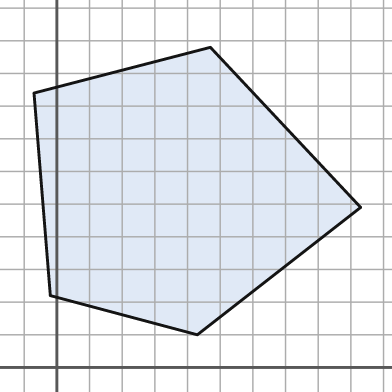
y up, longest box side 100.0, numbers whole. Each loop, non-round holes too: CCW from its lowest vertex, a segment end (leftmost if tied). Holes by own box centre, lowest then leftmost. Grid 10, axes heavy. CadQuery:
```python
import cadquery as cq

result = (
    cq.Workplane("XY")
    .moveTo(43.0, 10.0)
    .lineTo(93.0, 49.0)
    .lineTo(47.0, 98.0)
    .lineTo(-7.0, 84.0)
    .lineTo(-2.0, 22.0)
    .close()
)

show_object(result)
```